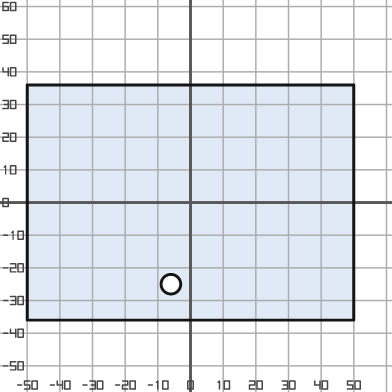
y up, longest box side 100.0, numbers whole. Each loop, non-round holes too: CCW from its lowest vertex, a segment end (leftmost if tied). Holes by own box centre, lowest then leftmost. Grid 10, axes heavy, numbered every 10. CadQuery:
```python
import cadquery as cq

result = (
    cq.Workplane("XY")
    .moveTo(-50.0, -36.0)
    .lineTo(50.0, -36.0)
    .lineTo(50.0, 36.0)
    .lineTo(-50.0, 36.0)
    .close()
    .moveTo(-6.0, -25.0)
    .circle(3.0)
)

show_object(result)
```